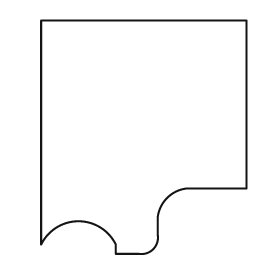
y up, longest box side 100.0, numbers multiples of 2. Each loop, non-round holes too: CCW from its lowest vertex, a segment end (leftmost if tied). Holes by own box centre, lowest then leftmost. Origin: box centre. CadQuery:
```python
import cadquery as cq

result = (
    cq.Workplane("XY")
    .moveTo(-12.0, -50.0)
    .lineTo(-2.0, -50.0)
    .threePointArc((4.0, -48.0), (6.0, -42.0))
    .lineTo(6.0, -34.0)
    .threePointArc((10.0, -26.0), (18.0, -22.0))
    .lineTo(44.0, -22.0)
    .lineTo(44.0, 50.0)
    .lineTo(-44.0, 50.0)
    .lineTo(-44.0, -46.0)
    .threePointArc((-28.0, -36.0), (-12.0, -46.0))
    .close()
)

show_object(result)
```